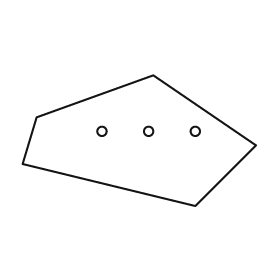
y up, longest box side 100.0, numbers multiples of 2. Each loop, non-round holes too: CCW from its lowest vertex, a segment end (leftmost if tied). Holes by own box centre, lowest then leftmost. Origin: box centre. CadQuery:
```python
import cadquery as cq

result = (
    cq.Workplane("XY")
    .moveTo(24.0, -28.0)
    .lineTo(50.0, -2.0)
    .lineTo(6.0, 28.0)
    .lineTo(-44.0, 10.0)
    .lineTo(-50.0, -10.0)
    .close()
    .moveTo(-16.0, 4.0)
    .circle(2.0)
    .moveTo(4.0, 4.0)
    .circle(2.0)
    .moveTo(24.0, 4.0)
    .circle(2.0)
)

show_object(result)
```